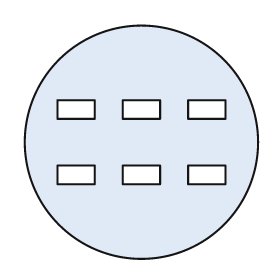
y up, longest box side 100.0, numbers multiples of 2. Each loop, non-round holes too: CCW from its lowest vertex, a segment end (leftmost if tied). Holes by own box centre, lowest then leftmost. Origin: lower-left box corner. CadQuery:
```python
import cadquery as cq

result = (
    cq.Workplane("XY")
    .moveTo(50.0, 50.0)
    .circle(50.0)
    .moveTo(14.0, 32.0)
    .lineTo(30.0, 32.0)
    .lineTo(30.0, 40.0)
    .lineTo(14.0, 40.0)
    .close()
    .moveTo(42.0, 32.0)
    .lineTo(58.0, 32.0)
    .lineTo(58.0, 40.0)
    .lineTo(42.0, 40.0)
    .close()
    .moveTo(70.0, 32.0)
    .lineTo(86.0, 32.0)
    .lineTo(86.0, 40.0)
    .lineTo(70.0, 40.0)
    .close()
    .moveTo(14.0, 60.0)
    .lineTo(30.0, 60.0)
    .lineTo(30.0, 68.0)
    .lineTo(14.0, 68.0)
    .close()
    .moveTo(42.0, 60.0)
    .lineTo(58.0, 60.0)
    .lineTo(58.0, 68.0)
    .lineTo(42.0, 68.0)
    .close()
    .moveTo(70.0, 60.0)
    .lineTo(86.0, 60.0)
    .lineTo(86.0, 68.0)
    .lineTo(70.0, 68.0)
    .close()
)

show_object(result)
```